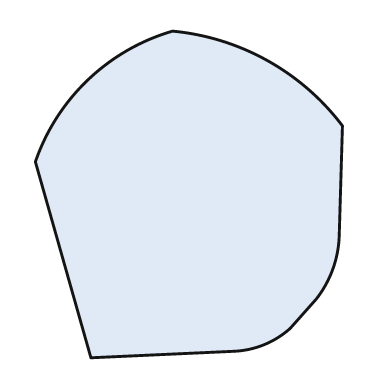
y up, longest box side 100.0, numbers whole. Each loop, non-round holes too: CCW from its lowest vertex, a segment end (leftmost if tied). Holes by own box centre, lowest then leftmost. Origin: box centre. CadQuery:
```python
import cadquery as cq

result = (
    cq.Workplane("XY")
    .moveTo(-30.0, -50.0)
    .lineTo(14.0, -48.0)
    .threePointArc((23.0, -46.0), (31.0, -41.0))
    .lineTo(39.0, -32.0)
    .threePointArc((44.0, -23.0), (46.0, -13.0))
    .lineTo(47.0, 21.0)
    .threePointArc((24.0, 41.0), (-5.0, 50.0))
    .threePointArc((-31.0, 35.0), (-47.0, 10.0))
    .close()
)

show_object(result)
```